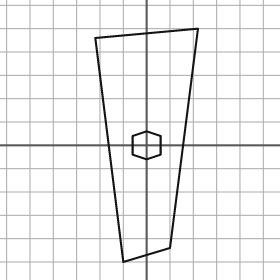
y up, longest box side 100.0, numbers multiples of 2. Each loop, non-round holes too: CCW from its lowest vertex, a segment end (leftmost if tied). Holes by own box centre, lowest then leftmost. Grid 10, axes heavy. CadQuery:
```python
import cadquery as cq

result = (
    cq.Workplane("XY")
    .moveTo(-10.0, -50.0)
    .lineTo(10.0, -44.0)
    .lineTo(22.0, 50.0)
    .lineTo(-22.0, 46.0)
    .close()
    .moveTo(0.0, -6.0)
    .lineTo(6.0, -4.0)
    .lineTo(6.0, 4.0)
    .lineTo(0.0, 6.0)
    .lineTo(-6.0, 4.0)
    .lineTo(-6.0, -4.0)
    .close()
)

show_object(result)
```